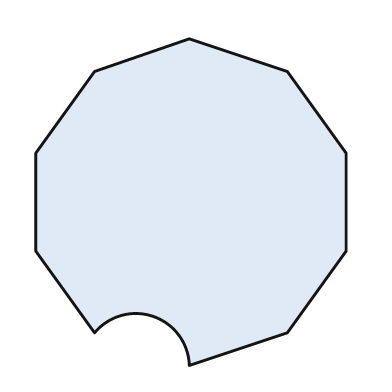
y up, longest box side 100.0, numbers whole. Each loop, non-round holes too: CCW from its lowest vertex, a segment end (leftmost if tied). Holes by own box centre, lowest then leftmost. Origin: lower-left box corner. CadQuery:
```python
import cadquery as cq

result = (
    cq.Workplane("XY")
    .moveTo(47.0, 0.0)
    .lineTo(77.0, 10.0)
    .lineTo(95.0, 35.0)
    .lineTo(95.0, 65.0)
    .lineTo(77.0, 90.0)
    .lineTo(47.0, 100.0)
    .lineTo(18.0, 90.0)
    .lineTo(0.0, 65.0)
    .lineTo(0.0, 35.0)
    .lineTo(18.0, 10.0)
    .threePointArc((36.0, 15.0), (47.0, 0.0))
    .close()
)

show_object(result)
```